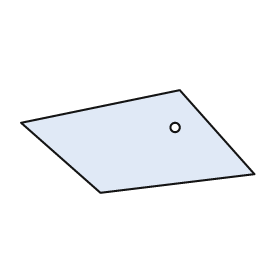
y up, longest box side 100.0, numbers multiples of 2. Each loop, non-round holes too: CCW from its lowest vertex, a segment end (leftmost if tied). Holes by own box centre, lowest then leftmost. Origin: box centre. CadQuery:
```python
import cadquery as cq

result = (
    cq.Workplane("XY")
    .moveTo(-16.0, -22.0)
    .lineTo(50.0, -14.0)
    .lineTo(18.0, 22.0)
    .lineTo(-50.0, 8.0)
    .close()
    .moveTo(16.0, 6.0)
    .circle(2.0)
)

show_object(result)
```